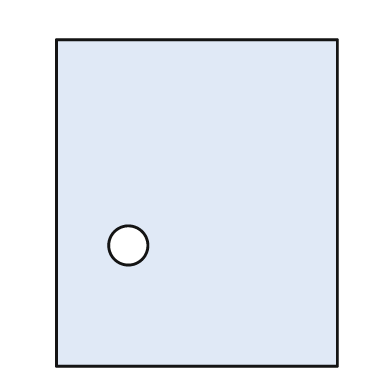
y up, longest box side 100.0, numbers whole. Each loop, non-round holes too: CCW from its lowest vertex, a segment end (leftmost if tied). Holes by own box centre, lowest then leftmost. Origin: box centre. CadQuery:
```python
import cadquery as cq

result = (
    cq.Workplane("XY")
    .moveTo(-43.0, -50.0)
    .lineTo(43.0, -50.0)
    .lineTo(43.0, 50.0)
    .lineTo(-43.0, 50.0)
    .close()
    .moveTo(-21.0, -13.0)
    .circle(6.0)
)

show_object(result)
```